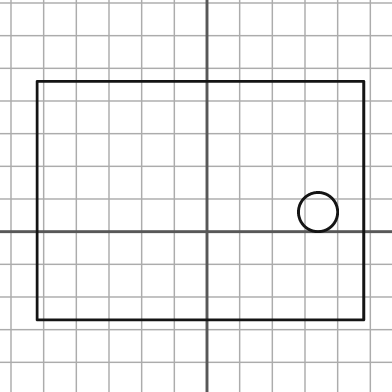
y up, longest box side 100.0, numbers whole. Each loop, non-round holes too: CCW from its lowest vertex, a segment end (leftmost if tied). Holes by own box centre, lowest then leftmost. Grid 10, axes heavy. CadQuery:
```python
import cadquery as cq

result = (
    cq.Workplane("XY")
    .moveTo(-52.0, -27.0)
    .lineTo(48.0, -27.0)
    .lineTo(48.0, 46.0)
    .lineTo(-52.0, 46.0)
    .close()
    .moveTo(34.0, 6.0)
    .circle(6.0)
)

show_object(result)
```